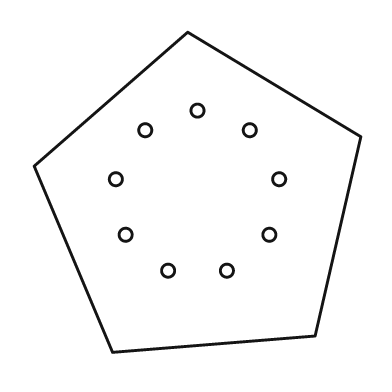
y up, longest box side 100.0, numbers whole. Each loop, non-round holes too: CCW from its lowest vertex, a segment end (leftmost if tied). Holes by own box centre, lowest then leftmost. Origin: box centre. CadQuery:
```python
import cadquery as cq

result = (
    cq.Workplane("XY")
    .moveTo(-26.0, -49.0)
    .lineTo(36.0, -44.0)
    .lineTo(50.0, 17.0)
    .lineTo(-3.0, 49.0)
    .lineTo(-50.0, 8.0)
    .close()
    .moveTo(-9.0, -24.0)
    .circle(2.0)
    .moveTo(9.0, -24.0)
    .circle(2.0)
    .moveTo(-22.0, -13.0)
    .circle(2.0)
    .moveTo(22.0, -13.0)
    .circle(2.0)
    .moveTo(-25.0, 4.0)
    .circle(2.0)
    .moveTo(25.0, 4.0)
    .circle(2.0)
    .moveTo(-16.0, 19.0)
    .circle(2.0)
    .moveTo(16.0, 19.0)
    .circle(2.0)
    .moveTo(0.0, 25.0)
    .circle(2.0)
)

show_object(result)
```